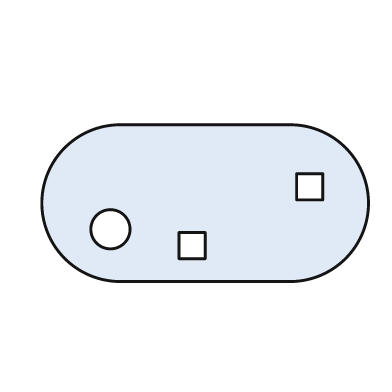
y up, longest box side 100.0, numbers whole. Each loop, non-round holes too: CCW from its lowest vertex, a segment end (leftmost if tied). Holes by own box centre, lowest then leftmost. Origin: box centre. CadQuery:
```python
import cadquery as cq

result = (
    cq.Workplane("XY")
    .moveTo(-26.0, -24.0)
    .lineTo(26.0, -24.0)
    .threePointArc((50.0, 0.0), (26.0, 24.0))
    .lineTo(-26.0, 24.0)
    .threePointArc((-50.0, 0.0), (-26.0, -24.0))
    .close()
    .moveTo(-8.0, -17.0)
    .lineTo(0.0, -17.0)
    .lineTo(0.0, -9.0)
    .lineTo(-8.0, -9.0)
    .close()
    .moveTo(-29.0, -8.0)
    .circle(6.0)
    .moveTo(28.0, 1.0)
    .lineTo(36.0, 1.0)
    .lineTo(36.0, 9.0)
    .lineTo(28.0, 9.0)
    .close()
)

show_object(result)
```